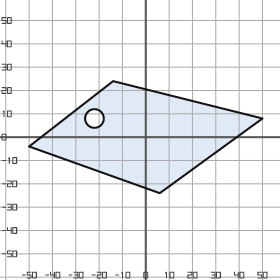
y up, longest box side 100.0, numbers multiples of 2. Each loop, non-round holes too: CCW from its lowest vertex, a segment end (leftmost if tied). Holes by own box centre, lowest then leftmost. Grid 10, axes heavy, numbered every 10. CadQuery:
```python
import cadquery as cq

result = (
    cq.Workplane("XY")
    .moveTo(6.0, -24.0)
    .lineTo(50.0, 8.0)
    .lineTo(-14.0, 24.0)
    .lineTo(-50.0, -4.0)
    .close()
    .moveTo(-22.0, 8.0)
    .circle(4.0)
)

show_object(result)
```